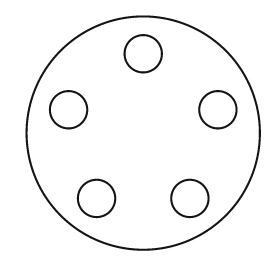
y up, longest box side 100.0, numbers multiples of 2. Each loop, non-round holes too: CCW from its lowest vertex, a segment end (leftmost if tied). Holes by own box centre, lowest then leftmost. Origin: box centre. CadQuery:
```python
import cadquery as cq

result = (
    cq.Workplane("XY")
    .moveTo(0.0, 0.0)
    .circle(50.0)
    .moveTo(-20.0, -28.0)
    .circle(8.0)
    .moveTo(20.0, -28.0)
    .circle(8.0)
    .moveTo(-32.0, 10.0)
    .circle(8.0)
    .moveTo(32.0, 10.0)
    .circle(8.0)
    .moveTo(0.0, 34.0)
    .circle(8.0)
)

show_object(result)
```